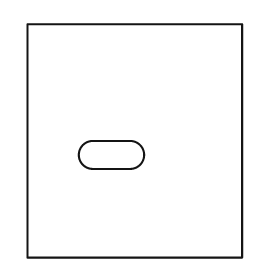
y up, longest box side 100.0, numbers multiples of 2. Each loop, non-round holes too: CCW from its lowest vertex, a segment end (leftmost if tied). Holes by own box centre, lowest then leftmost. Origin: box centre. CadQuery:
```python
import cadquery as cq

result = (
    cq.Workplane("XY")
    .moveTo(-46.0, -50.0)
    .lineTo(46.0, -50.0)
    .lineTo(46.0, 50.0)
    .lineTo(-46.0, 50.0)
    .close()
    .moveTo(-18.0, -12.0)
    .lineTo(-2.0, -12.0)
    .threePointArc((4.0, -6.0), (-2.0, 0.0))
    .lineTo(-18.0, 0.0)
    .threePointArc((-24.0, -6.0), (-18.0, -12.0))
    .close()
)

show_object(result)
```